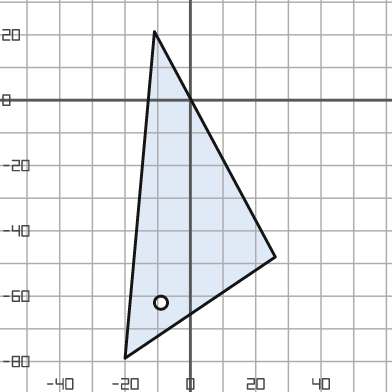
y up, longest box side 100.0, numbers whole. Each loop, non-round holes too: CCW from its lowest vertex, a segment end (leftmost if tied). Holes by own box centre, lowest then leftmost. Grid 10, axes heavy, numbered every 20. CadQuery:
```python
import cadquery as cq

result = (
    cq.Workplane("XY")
    .moveTo(-20.0, -79.0)
    .lineTo(26.0, -48.0)
    .lineTo(-11.0, 21.0)
    .close()
    .moveTo(-9.0, -62.0)
    .circle(2.0)
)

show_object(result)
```